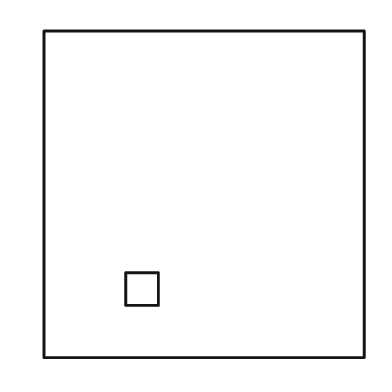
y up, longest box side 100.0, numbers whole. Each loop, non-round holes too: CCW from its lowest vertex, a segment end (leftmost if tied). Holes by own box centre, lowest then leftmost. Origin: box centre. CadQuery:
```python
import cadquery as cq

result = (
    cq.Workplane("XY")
    .moveTo(-49.0, -50.0)
    .lineTo(49.0, -50.0)
    .lineTo(49.0, 50.0)
    .lineTo(-49.0, 50.0)
    .close()
    .moveTo(-24.0, -34.0)
    .lineTo(-14.0, -34.0)
    .lineTo(-14.0, -24.0)
    .lineTo(-24.0, -24.0)
    .close()
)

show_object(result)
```